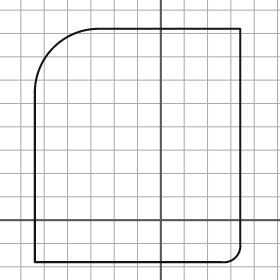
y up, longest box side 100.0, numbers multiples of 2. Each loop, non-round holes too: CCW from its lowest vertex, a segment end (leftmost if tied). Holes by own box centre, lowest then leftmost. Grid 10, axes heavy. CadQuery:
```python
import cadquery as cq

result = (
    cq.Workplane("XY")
    .moveTo(-54.0, -18.0)
    .lineTo(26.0, -18.0)
    .threePointArc((32.0, -16.0), (34.0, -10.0))
    .lineTo(34.0, 82.0)
    .lineTo(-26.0, 82.0)
    .threePointArc((-46.0, 74.0), (-54.0, 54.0))
    .close()
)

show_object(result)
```